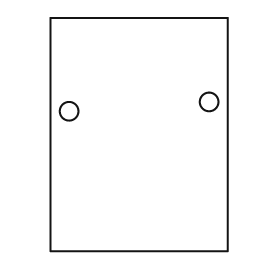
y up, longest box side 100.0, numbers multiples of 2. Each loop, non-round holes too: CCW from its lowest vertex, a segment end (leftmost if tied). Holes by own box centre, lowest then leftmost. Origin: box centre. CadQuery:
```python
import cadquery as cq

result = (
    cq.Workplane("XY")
    .moveTo(-38.0, -50.0)
    .lineTo(38.0, -50.0)
    .lineTo(38.0, 50.0)
    .lineTo(-38.0, 50.0)
    .close()
    .moveTo(-30.0, 10.0)
    .circle(4.0)
    .moveTo(30.0, 14.0)
    .circle(4.0)
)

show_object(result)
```